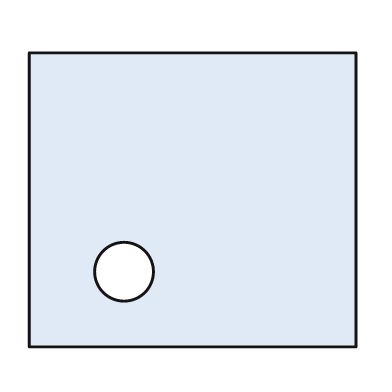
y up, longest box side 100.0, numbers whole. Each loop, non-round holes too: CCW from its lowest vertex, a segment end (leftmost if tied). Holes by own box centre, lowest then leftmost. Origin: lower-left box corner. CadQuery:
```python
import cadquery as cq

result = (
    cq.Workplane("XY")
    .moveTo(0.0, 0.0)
    .lineTo(100.0, 0.0)
    .lineTo(100.0, 90.0)
    .lineTo(0.0, 90.0)
    .close()
    .moveTo(29.0, 23.0)
    .circle(9.0)
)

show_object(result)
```